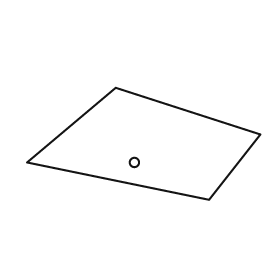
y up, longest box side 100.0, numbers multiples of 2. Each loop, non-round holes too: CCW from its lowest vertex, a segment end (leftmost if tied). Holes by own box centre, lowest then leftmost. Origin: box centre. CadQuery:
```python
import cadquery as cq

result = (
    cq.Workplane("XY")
    .moveTo(28.0, -24.0)
    .lineTo(50.0, 4.0)
    .lineTo(-12.0, 24.0)
    .lineTo(-50.0, -8.0)
    .close()
    .moveTo(-4.0, -8.0)
    .circle(2.0)
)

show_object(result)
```